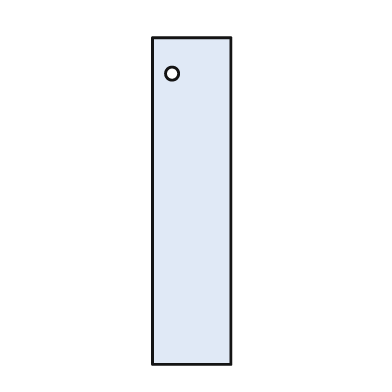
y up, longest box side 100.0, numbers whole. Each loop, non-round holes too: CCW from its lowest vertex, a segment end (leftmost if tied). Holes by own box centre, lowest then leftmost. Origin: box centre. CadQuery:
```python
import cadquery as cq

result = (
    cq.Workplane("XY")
    .moveTo(-12.0, -50.0)
    .lineTo(12.0, -50.0)
    .lineTo(12.0, 50.0)
    .lineTo(-12.0, 50.0)
    .close()
    .moveTo(-6.0, 39.0)
    .circle(2.0)
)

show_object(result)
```